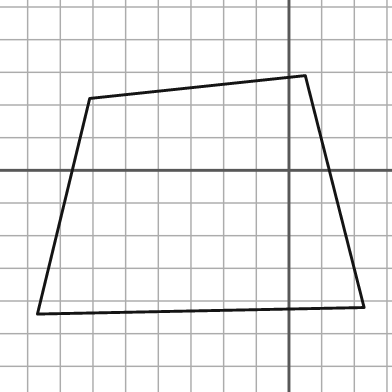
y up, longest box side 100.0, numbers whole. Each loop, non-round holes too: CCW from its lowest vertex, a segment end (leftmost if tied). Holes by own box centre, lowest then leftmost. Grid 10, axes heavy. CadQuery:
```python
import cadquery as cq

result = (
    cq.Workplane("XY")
    .moveTo(-77.0, -44.0)
    .lineTo(23.0, -42.0)
    .lineTo(5.0, 29.0)
    .lineTo(-61.0, 22.0)
    .close()
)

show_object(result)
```